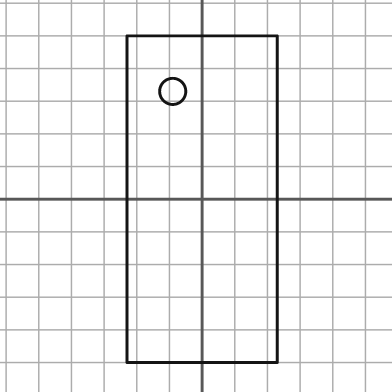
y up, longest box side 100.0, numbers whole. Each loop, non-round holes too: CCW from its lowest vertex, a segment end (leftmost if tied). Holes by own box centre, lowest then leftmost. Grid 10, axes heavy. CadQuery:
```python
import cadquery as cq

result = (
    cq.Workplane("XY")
    .moveTo(-23.0, -50.0)
    .lineTo(23.0, -50.0)
    .lineTo(23.0, 50.0)
    .lineTo(-23.0, 50.0)
    .close()
    .moveTo(-9.0, 33.0)
    .circle(4.0)
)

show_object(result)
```